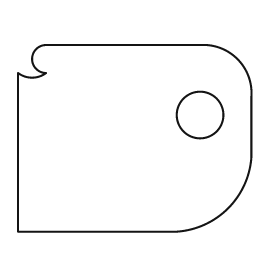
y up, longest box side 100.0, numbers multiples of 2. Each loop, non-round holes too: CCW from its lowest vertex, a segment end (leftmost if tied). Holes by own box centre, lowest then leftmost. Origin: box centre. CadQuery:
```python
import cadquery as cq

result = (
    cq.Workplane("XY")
    .moveTo(-50.0, -40.0)
    .lineTo(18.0, -40.0)
    .threePointArc((40.0, -30.0), (50.0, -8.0))
    .lineTo(50.0, 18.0)
    .threePointArc((44.0, 34.0), (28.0, 40.0))
    .lineTo(-38.0, 40.0)
    .threePointArc((-44.0, 34.0), (-38.0, 28.0))
    .threePointArc((-44.0, 26.0), (-50.0, 28.0))
    .close()
    .moveTo(28.0, 10.0)
    .circle(10.0)
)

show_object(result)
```